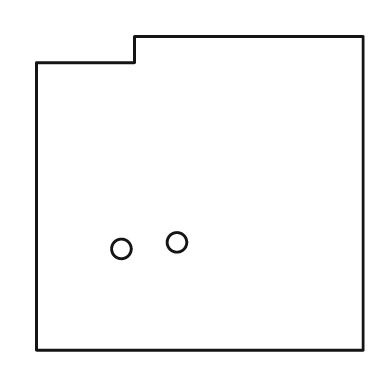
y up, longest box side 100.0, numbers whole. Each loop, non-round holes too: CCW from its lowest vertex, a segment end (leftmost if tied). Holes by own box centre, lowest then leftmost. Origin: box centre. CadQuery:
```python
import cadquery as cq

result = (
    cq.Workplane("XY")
    .moveTo(-50.0, -48.0)
    .lineTo(50.0, -48.0)
    .lineTo(50.0, 48.0)
    .lineTo(-20.0, 48.0)
    .lineTo(-20.0, 40.0)
    .lineTo(-50.0, 40.0)
    .close()
    .moveTo(-24.0, -17.0)
    .circle(3.0)
    .moveTo(-7.0, -15.0)
    .circle(3.0)
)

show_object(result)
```